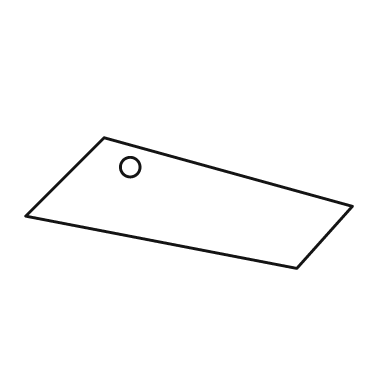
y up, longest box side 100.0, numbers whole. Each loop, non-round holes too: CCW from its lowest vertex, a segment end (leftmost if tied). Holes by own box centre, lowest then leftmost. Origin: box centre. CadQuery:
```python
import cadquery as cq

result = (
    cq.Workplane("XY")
    .moveTo(33.0, -20.0)
    .lineTo(50.0, -1.0)
    .lineTo(-26.0, 20.0)
    .lineTo(-50.0, -4.0)
    .close()
    .moveTo(-18.0, 11.0)
    .circle(3.0)
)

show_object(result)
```